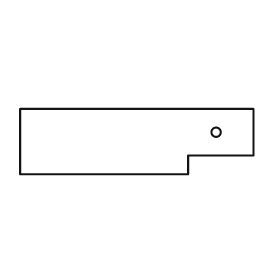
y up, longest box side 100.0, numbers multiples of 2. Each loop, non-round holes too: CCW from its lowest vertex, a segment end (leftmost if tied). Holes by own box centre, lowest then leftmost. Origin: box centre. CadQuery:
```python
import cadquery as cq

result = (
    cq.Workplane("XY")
    .moveTo(-50.0, -14.0)
    .lineTo(22.0, -14.0)
    .lineTo(22.0, -6.0)
    .lineTo(50.0, -6.0)
    .lineTo(50.0, 14.0)
    .lineTo(-50.0, 14.0)
    .close()
    .moveTo(34.0, 4.0)
    .circle(2.0)
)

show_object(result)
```